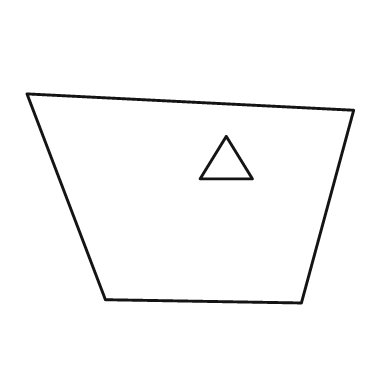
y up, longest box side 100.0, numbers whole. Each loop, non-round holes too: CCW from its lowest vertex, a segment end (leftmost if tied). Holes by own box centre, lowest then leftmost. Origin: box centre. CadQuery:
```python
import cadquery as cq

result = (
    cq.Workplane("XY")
    .moveTo(34.0, -32.0)
    .lineTo(50.0, 27.0)
    .lineTo(-50.0, 32.0)
    .lineTo(-26.0, -31.0)
    .close()
    .moveTo(3.0, 6.0)
    .lineTo(19.0, 6.0)
    .lineTo(11.0, 19.0)
    .close()
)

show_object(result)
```